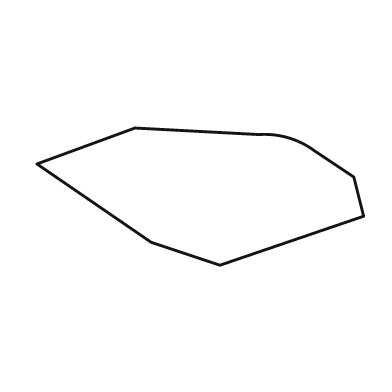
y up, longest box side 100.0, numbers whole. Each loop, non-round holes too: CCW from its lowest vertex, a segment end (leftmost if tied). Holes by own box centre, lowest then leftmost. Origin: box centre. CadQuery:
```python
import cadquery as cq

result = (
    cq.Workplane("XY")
    .moveTo(6.0, -21.0)
    .lineTo(50.0, -6.0)
    .lineTo(47.0, 6.0)
    .lineTo(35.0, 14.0)
    .threePointArc((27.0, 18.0), (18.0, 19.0))
    .lineTo(-20.0, 21.0)
    .lineTo(-50.0, 10.0)
    .lineTo(-15.0, -14.0)
    .close()
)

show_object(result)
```